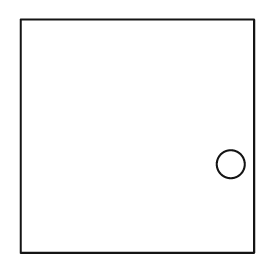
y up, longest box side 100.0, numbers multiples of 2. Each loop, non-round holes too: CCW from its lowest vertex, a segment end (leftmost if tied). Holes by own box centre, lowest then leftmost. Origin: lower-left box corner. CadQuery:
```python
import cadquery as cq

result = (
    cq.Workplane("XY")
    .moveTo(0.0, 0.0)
    .lineTo(100.0, 0.0)
    .lineTo(100.0, 100.0)
    .lineTo(0.0, 100.0)
    .close()
    .moveTo(90.0, 38.0)
    .circle(6.0)
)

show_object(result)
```